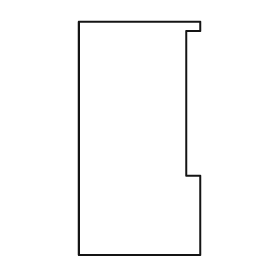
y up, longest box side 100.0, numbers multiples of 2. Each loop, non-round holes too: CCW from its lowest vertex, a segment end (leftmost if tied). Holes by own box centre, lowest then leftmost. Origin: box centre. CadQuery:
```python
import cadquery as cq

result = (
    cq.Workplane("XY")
    .moveTo(-26.0, -50.0)
    .lineTo(26.0, -50.0)
    .lineTo(26.0, -16.0)
    .lineTo(20.0, -16.0)
    .lineTo(20.0, 46.0)
    .lineTo(26.0, 46.0)
    .lineTo(26.0, 50.0)
    .lineTo(-26.0, 50.0)
    .close()
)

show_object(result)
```